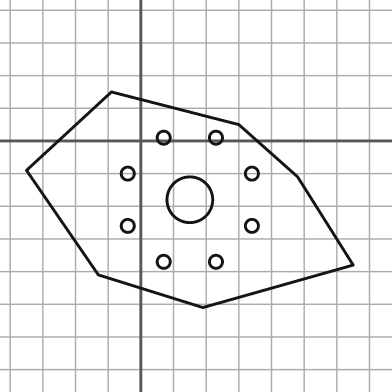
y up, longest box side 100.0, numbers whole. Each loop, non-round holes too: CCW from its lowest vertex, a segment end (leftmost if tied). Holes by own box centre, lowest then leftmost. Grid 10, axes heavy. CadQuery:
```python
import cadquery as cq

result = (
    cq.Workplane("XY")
    .moveTo(19.0, -51.0)
    .lineTo(65.0, -38.0)
    .lineTo(48.0, -11.0)
    .lineTo(30.0, 5.0)
    .lineTo(-9.0, 15.0)
    .lineTo(-35.0, -9.0)
    .lineTo(-13.0, -41.0)
    .close()
    .moveTo(7.0, -37.0)
    .circle(2.0)
    .moveTo(23.0, -37.0)
    .circle(2.0)
    .moveTo(-4.0, -26.0)
    .circle(2.0)
    .moveTo(34.0, -26.0)
    .circle(2.0)
    .moveTo(15.0, -18.0)
    .circle(7.0)
    .moveTo(-4.0, -10.0)
    .circle(2.0)
    .moveTo(34.0, -10.0)
    .circle(2.0)
    .moveTo(7.0, 1.0)
    .circle(2.0)
    .moveTo(23.0, 1.0)
    .circle(2.0)
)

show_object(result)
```